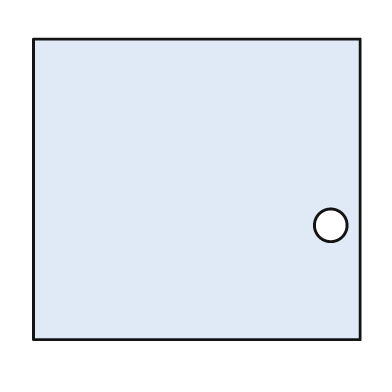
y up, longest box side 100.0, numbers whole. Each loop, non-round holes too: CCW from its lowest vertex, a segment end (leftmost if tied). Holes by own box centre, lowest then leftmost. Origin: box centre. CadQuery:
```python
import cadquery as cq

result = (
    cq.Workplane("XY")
    .moveTo(-50.0, -46.0)
    .lineTo(50.0, -46.0)
    .lineTo(50.0, 46.0)
    .lineTo(-50.0, 46.0)
    .close()
    .moveTo(41.0, -11.0)
    .circle(5.0)
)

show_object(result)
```